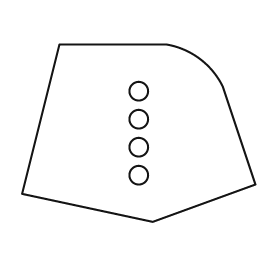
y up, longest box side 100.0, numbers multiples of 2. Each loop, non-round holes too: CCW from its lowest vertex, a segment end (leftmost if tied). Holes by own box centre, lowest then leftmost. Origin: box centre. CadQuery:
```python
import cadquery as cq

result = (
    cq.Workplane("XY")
    .moveTo(6.0, -38.0)
    .lineTo(50.0, -22.0)
    .lineTo(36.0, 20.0)
    .threePointArc((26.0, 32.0), (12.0, 38.0))
    .lineTo(-34.0, 38.0)
    .lineTo(-50.0, -26.0)
    .close()
    .moveTo(0.0, -18.0)
    .circle(4.0)
    .moveTo(0.0, -6.0)
    .circle(4.0)
    .moveTo(0.0, 6.0)
    .circle(4.0)
    .moveTo(0.0, 18.0)
    .circle(4.0)
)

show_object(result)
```